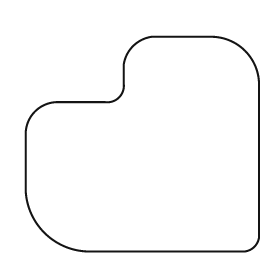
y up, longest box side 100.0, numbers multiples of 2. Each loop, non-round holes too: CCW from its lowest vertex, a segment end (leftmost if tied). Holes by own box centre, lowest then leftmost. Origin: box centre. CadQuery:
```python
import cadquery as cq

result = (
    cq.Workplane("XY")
    .moveTo(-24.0, -46.0)
    .lineTo(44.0, -46.0)
    .threePointArc((48.0, -44.0), (50.0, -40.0))
    .lineTo(50.0, 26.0)
    .threePointArc((44.0, 40.0), (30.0, 46.0))
    .lineTo(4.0, 46.0)
    .threePointArc((-4.0, 42.0), (-8.0, 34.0))
    .lineTo(-8.0, 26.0)
    .threePointArc((-10.0, 20.0), (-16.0, 18.0))
    .lineTo(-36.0, 18.0)
    .threePointArc((-46.0, 14.0), (-50.0, 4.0))
    .lineTo(-50.0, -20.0)
    .threePointArc((-42.0, -38.0), (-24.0, -46.0))
    .close()
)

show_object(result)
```